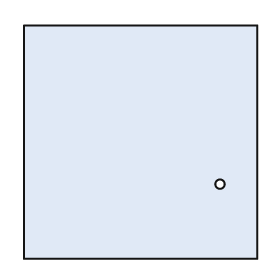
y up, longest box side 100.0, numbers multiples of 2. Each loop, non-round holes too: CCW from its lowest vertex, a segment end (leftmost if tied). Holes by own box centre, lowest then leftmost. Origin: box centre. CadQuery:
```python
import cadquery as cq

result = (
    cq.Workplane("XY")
    .moveTo(-50.0, -50.0)
    .lineTo(50.0, -50.0)
    .lineTo(50.0, 50.0)
    .lineTo(-50.0, 50.0)
    .close()
    .moveTo(34.0, -18.0)
    .circle(2.0)
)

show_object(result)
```